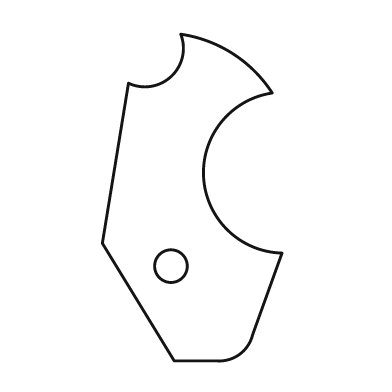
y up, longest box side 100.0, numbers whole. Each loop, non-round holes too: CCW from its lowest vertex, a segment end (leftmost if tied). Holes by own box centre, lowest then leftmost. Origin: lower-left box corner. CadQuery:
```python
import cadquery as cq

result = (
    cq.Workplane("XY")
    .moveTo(22.0, 0.0)
    .lineTo(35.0, 0.0)
    .threePointArc((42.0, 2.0), (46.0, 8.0))
    .lineTo(55.0, 33.0)
    .threePointArc((31.0, 56.0), (52.0, 82.0))
    .threePointArc((40.0, 94.0), (24.0, 100.0))
    .threePointArc((21.0, 87.0), (8.0, 85.0))
    .lineTo(0.0, 36.0)
    .close()
    .moveTo(21.0, 29.0)
    .circle(5.0)
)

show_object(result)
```